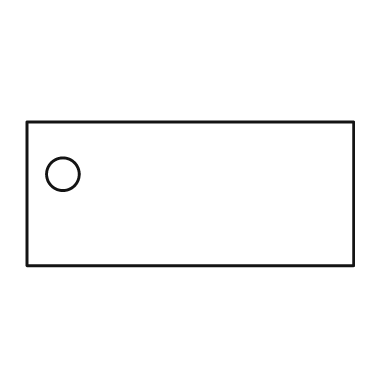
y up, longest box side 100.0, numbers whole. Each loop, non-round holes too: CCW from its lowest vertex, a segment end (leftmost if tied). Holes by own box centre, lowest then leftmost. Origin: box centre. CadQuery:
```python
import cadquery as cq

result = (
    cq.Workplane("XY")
    .moveTo(-50.0, -22.0)
    .lineTo(50.0, -22.0)
    .lineTo(50.0, 22.0)
    .lineTo(-50.0, 22.0)
    .close()
    .moveTo(-39.0, 6.0)
    .circle(5.0)
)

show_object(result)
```